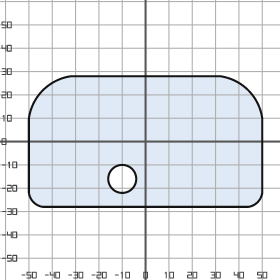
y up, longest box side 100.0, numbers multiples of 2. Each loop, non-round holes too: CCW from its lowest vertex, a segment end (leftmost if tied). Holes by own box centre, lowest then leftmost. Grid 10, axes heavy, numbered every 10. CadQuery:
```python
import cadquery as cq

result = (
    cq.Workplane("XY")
    .moveTo(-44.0, -28.0)
    .lineTo(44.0, -28.0)
    .threePointArc((48.0, -26.0), (50.0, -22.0))
    .lineTo(50.0, 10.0)
    .threePointArc((44.0, 22.0), (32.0, 28.0))
    .lineTo(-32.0, 28.0)
    .threePointArc((-44.0, 22.0), (-50.0, 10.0))
    .lineTo(-50.0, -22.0)
    .threePointArc((-48.0, -26.0), (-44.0, -28.0))
    .close()
    .moveTo(-10.0, -16.0)
    .circle(6.0)
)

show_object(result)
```